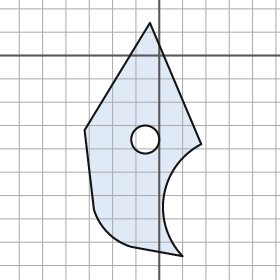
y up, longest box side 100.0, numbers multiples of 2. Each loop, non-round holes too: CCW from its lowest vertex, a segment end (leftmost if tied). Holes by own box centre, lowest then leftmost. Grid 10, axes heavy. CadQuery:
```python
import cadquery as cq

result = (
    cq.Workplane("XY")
    .moveTo(10.0, -86.0)
    .threePointArc((2.0, -60.0), (18.0, -38.0))
    .lineTo(-4.0, 14.0)
    .lineTo(-32.0, -32.0)
    .lineTo(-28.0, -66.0)
    .threePointArc((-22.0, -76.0), (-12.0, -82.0))
    .close()
    .moveTo(-6.0, -36.0)
    .circle(6.0)
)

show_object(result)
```